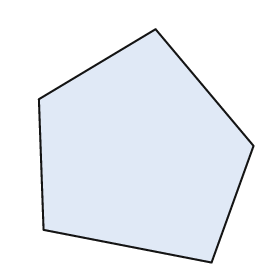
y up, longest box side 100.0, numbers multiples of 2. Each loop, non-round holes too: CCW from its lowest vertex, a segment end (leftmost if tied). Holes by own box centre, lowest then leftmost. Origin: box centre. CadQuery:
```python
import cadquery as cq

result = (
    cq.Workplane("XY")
    .moveTo(28.0, -50.0)
    .lineTo(46.0, 0.0)
    .lineTo(4.0, 50.0)
    .lineTo(-46.0, 20.0)
    .lineTo(-44.0, -36.0)
    .close()
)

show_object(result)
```